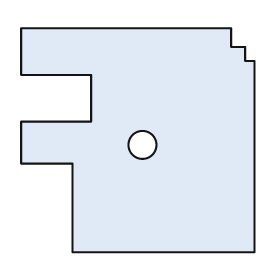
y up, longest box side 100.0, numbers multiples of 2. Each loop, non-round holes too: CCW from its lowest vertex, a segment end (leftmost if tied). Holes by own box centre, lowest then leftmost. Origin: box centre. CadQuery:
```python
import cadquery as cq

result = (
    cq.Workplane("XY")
    .moveTo(-28.0, -48.0)
    .lineTo(50.0, -48.0)
    .lineTo(50.0, 34.0)
    .lineTo(46.0, 34.0)
    .lineTo(46.0, 40.0)
    .lineTo(40.0, 40.0)
    .lineTo(40.0, 48.0)
    .lineTo(-50.0, 48.0)
    .lineTo(-50.0, 28.0)
    .lineTo(-20.0, 28.0)
    .lineTo(-20.0, 8.0)
    .lineTo(-50.0, 8.0)
    .lineTo(-50.0, -10.0)
    .lineTo(-28.0, -10.0)
    .close()
    .moveTo(2.0, -2.0)
    .circle(6.0)
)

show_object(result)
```